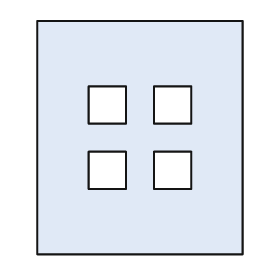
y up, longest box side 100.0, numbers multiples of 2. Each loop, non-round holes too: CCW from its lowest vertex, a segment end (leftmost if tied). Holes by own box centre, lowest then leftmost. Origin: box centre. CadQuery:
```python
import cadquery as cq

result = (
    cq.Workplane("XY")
    .moveTo(-44.0, -50.0)
    .lineTo(44.0, -50.0)
    .lineTo(44.0, 50.0)
    .lineTo(-44.0, 50.0)
    .close()
    .moveTo(-22.0, -22.0)
    .lineTo(-6.0, -22.0)
    .lineTo(-6.0, -6.0)
    .lineTo(-22.0, -6.0)
    .close()
    .moveTo(6.0, -22.0)
    .lineTo(22.0, -22.0)
    .lineTo(22.0, -6.0)
    .lineTo(6.0, -6.0)
    .close()
    .moveTo(-22.0, 6.0)
    .lineTo(-6.0, 6.0)
    .lineTo(-6.0, 22.0)
    .lineTo(-22.0, 22.0)
    .close()
    .moveTo(6.0, 6.0)
    .lineTo(22.0, 6.0)
    .lineTo(22.0, 22.0)
    .lineTo(6.0, 22.0)
    .close()
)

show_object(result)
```